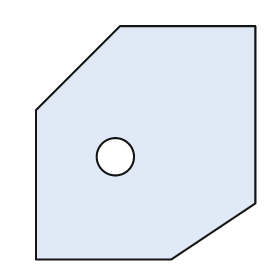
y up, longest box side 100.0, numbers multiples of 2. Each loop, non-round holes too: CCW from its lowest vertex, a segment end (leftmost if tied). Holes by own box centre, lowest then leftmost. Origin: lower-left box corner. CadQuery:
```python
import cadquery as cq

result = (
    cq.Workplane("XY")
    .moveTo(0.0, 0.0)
    .lineTo(58.0, 0.0)
    .lineTo(94.0, 24.0)
    .lineTo(94.0, 100.0)
    .lineTo(36.0, 100.0)
    .lineTo(0.0, 64.0)
    .close()
    .moveTo(34.0, 44.0)
    .circle(8.0)
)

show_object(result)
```